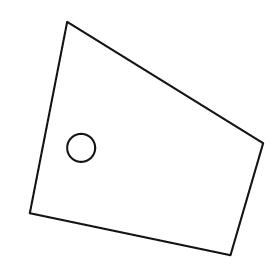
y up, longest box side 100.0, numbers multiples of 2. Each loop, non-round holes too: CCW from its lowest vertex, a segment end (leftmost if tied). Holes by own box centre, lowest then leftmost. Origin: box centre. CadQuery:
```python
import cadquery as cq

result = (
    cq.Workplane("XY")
    .moveTo(36.0, -50.0)
    .lineTo(50.0, -2.0)
    .lineTo(-34.0, 50.0)
    .lineTo(-50.0, -32.0)
    .close()
    .moveTo(-28.0, -4.0)
    .circle(6.0)
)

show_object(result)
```